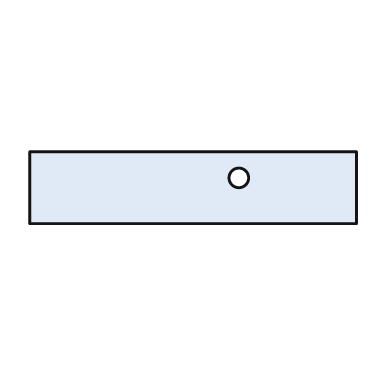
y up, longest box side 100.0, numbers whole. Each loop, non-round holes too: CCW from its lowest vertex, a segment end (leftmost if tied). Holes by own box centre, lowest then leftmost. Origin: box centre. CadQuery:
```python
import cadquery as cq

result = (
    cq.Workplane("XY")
    .moveTo(-50.0, -11.0)
    .lineTo(50.0, -11.0)
    .lineTo(50.0, 11.0)
    .lineTo(-50.0, 11.0)
    .close()
    .moveTo(14.0, 3.0)
    .circle(3.0)
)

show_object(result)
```